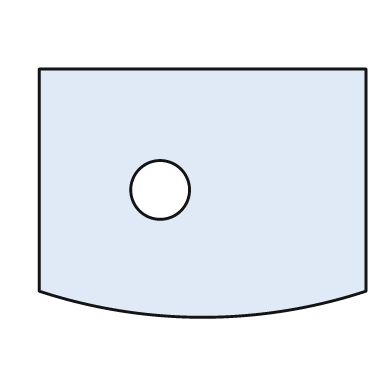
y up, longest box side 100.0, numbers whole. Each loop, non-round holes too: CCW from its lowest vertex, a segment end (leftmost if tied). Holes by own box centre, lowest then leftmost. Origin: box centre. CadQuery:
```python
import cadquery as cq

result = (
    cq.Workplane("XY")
    .moveTo(-50.0, -30.0)
    .threePointArc((0.0, -38.0), (50.0, -30.0))
    .lineTo(50.0, 38.0)
    .lineTo(-50.0, 38.0)
    .close()
    .moveTo(-13.0, 1.0)
    .circle(9.0)
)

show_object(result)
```